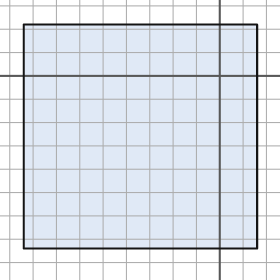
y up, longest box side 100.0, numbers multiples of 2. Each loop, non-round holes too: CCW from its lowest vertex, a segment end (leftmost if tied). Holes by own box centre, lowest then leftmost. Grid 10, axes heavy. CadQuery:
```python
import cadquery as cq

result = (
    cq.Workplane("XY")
    .moveTo(-84.0, -74.0)
    .lineTo(16.0, -74.0)
    .lineTo(16.0, 22.0)
    .lineTo(-84.0, 22.0)
    .close()
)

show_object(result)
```